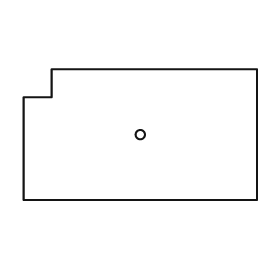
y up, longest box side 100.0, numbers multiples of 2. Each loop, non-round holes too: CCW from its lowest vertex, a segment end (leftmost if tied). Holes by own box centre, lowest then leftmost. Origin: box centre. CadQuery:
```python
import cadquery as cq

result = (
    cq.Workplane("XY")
    .moveTo(-50.0, -28.0)
    .lineTo(50.0, -28.0)
    .lineTo(50.0, 28.0)
    .lineTo(-38.0, 28.0)
    .lineTo(-38.0, 16.0)
    .lineTo(-50.0, 16.0)
    .close()
    .moveTo(0.0, 0.0)
    .circle(2.0)
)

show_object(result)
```